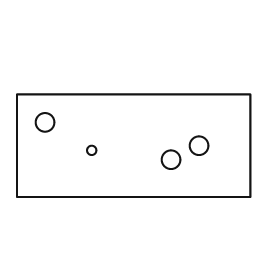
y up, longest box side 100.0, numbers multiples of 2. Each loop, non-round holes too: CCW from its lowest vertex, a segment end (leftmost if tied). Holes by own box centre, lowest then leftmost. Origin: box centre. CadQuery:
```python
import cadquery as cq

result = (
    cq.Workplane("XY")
    .moveTo(-50.0, -22.0)
    .lineTo(50.0, -22.0)
    .lineTo(50.0, 22.0)
    .lineTo(-50.0, 22.0)
    .close()
    .moveTo(16.0, -6.0)
    .circle(4.0)
    .moveTo(-18.0, -2.0)
    .circle(2.0)
    .moveTo(28.0, 0.0)
    .circle(4.0)
    .moveTo(-38.0, 10.0)
    .circle(4.0)
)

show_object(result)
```